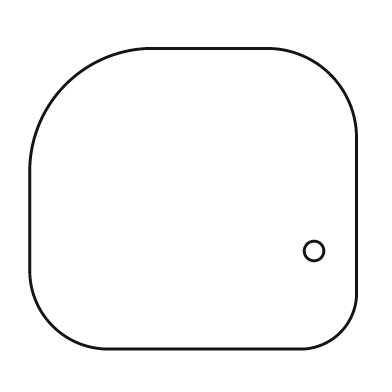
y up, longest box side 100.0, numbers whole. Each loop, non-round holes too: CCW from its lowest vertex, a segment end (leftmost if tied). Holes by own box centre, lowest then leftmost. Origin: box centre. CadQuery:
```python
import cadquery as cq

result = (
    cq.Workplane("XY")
    .moveTo(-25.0, -46.0)
    .lineTo(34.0, -46.0)
    .threePointArc((45.0, -41.0), (50.0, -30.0))
    .lineTo(50.0, 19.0)
    .threePointArc((42.0, 38.0), (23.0, 46.0))
    .lineTo(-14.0, 46.0)
    .threePointArc((-39.0, 35.0), (-50.0, 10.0))
    .lineTo(-50.0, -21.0)
    .threePointArc((-43.0, -39.0), (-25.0, -46.0))
    .close()
    .moveTo(37.0, -16.0)
    .circle(3.0)
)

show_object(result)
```